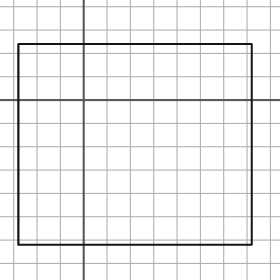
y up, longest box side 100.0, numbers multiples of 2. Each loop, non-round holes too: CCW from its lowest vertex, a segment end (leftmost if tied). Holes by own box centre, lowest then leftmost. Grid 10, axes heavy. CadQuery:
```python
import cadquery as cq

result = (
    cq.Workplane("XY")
    .moveTo(-28.0, -62.0)
    .lineTo(72.0, -62.0)
    .lineTo(72.0, 24.0)
    .lineTo(-28.0, 24.0)
    .close()
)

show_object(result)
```